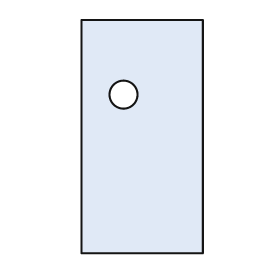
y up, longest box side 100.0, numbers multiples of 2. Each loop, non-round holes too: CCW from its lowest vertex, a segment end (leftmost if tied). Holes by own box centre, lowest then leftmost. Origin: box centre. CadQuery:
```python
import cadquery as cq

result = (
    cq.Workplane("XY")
    .moveTo(-26.0, -50.0)
    .lineTo(26.0, -50.0)
    .lineTo(26.0, 50.0)
    .lineTo(-26.0, 50.0)
    .close()
    .moveTo(-8.0, 18.0)
    .circle(6.0)
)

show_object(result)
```